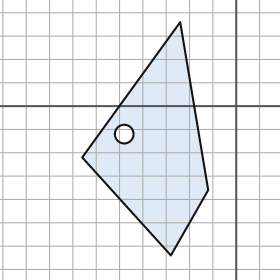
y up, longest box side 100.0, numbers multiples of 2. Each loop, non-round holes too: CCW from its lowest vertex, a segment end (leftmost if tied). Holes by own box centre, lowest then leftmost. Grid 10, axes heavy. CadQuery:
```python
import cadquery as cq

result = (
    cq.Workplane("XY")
    .moveTo(-28.0, -64.0)
    .lineTo(-12.0, -36.0)
    .lineTo(-24.0, 36.0)
    .lineTo(-66.0, -22.0)
    .close()
    .moveTo(-48.0, -12.0)
    .circle(4.0)
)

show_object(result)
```